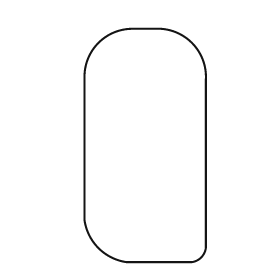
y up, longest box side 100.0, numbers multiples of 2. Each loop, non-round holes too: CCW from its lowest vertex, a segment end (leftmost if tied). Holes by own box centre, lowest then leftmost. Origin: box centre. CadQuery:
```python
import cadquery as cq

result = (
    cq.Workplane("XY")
    .moveTo(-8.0, -50.0)
    .lineTo(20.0, -50.0)
    .threePointArc((24.0, -48.0), (26.0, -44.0))
    .lineTo(26.0, 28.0)
    .threePointArc((20.0, 44.0), (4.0, 50.0))
    .lineTo(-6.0, 50.0)
    .threePointArc((-20.0, 44.0), (-26.0, 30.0))
    .lineTo(-26.0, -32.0)
    .threePointArc((-20.0, -44.0), (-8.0, -50.0))
    .close()
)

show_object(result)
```